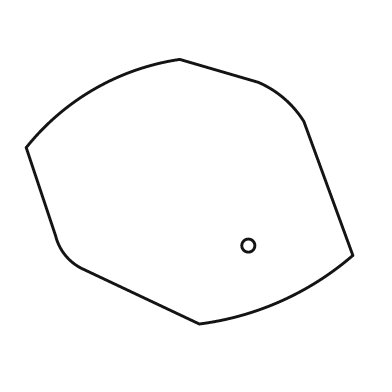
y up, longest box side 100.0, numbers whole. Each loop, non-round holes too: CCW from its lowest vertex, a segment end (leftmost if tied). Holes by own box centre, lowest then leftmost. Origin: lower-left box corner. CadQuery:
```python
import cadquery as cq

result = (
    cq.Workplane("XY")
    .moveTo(53.0, 0.0)
    .threePointArc((78.0, 7.0), (100.0, 21.0))
    .lineTo(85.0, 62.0)
    .threePointArc((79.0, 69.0), (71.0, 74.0))
    .lineTo(47.0, 81.0)
    .threePointArc((21.0, 72.0), (0.0, 54.0))
    .lineTo(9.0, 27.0)
    .threePointArc((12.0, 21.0), (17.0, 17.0))
    .close()
    .moveTo(68.0, 24.0)
    .circle(2.0)
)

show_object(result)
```